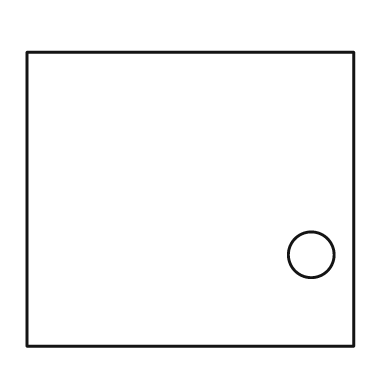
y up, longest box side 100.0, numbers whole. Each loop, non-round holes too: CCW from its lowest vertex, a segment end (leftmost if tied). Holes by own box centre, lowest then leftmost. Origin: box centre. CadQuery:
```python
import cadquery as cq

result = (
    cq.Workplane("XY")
    .moveTo(-50.0, -45.0)
    .lineTo(50.0, -45.0)
    .lineTo(50.0, 45.0)
    .lineTo(-50.0, 45.0)
    .close()
    .moveTo(37.0, -17.0)
    .circle(7.0)
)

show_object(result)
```